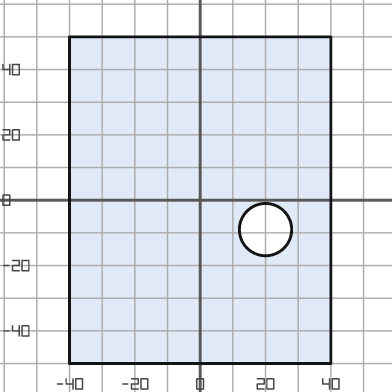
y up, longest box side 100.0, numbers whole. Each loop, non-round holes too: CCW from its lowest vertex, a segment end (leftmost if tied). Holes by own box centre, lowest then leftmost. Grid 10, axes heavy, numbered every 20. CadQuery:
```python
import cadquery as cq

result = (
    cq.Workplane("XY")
    .moveTo(-40.0, -50.0)
    .lineTo(40.0, -50.0)
    .lineTo(40.0, 50.0)
    .lineTo(-40.0, 50.0)
    .close()
    .moveTo(20.0, -9.0)
    .circle(8.0)
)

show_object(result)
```